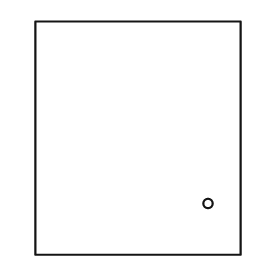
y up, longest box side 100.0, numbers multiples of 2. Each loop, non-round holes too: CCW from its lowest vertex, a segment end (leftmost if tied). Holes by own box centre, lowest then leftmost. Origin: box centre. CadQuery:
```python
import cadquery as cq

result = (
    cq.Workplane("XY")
    .moveTo(-44.0, -50.0)
    .lineTo(44.0, -50.0)
    .lineTo(44.0, 50.0)
    .lineTo(-44.0, 50.0)
    .close()
    .moveTo(30.0, -28.0)
    .circle(2.0)
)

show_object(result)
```